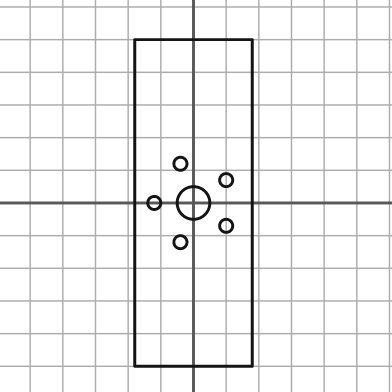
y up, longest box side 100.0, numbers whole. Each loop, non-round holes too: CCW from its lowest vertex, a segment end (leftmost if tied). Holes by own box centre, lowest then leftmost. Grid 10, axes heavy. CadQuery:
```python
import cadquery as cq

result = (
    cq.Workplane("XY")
    .moveTo(-18.0, -50.0)
    .lineTo(18.0, -50.0)
    .lineTo(18.0, 50.0)
    .lineTo(-18.0, 50.0)
    .close()
    .moveTo(-4.0, -12.0)
    .circle(2.0)
    .moveTo(10.0, -7.0)
    .circle(2.0)
    .moveTo(-12.0, 0.0)
    .circle(2.0)
    .moveTo(0.0, 0.0)
    .circle(5.0)
    .moveTo(10.0, 7.0)
    .circle(2.0)
    .moveTo(-4.0, 12.0)
    .circle(2.0)
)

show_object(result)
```